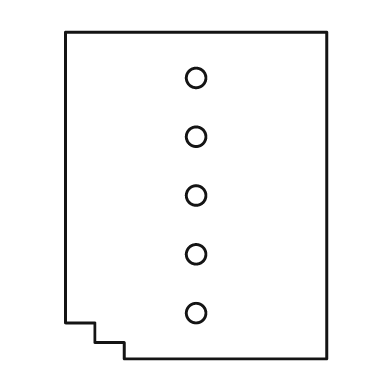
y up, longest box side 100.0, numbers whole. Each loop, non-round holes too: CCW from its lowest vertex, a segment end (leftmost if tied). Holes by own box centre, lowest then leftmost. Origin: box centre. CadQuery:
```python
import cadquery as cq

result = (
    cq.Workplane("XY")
    .moveTo(-22.0, -50.0)
    .lineTo(40.0, -50.0)
    .lineTo(40.0, 50.0)
    .lineTo(-40.0, 50.0)
    .lineTo(-40.0, -39.0)
    .lineTo(-31.0, -39.0)
    .lineTo(-31.0, -45.0)
    .lineTo(-22.0, -45.0)
    .close()
    .moveTo(0.0, -36.0)
    .circle(3.0)
    .moveTo(0.0, -18.0)
    .circle(3.0)
    .moveTo(0.0, 0.0)
    .circle(3.0)
    .moveTo(0.0, 18.0)
    .circle(3.0)
    .moveTo(0.0, 36.0)
    .circle(3.0)
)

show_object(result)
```